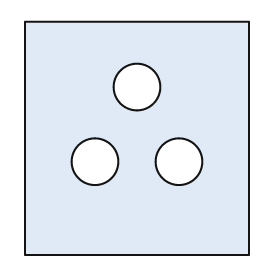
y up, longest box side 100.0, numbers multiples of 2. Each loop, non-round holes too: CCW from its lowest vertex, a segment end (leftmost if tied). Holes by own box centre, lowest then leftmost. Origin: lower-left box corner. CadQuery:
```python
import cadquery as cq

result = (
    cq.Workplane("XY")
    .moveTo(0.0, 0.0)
    .lineTo(96.0, 0.0)
    .lineTo(96.0, 100.0)
    .lineTo(0.0, 100.0)
    .close()
    .moveTo(30.0, 40.0)
    .circle(10.0)
    .moveTo(66.0, 40.0)
    .circle(10.0)
    .moveTo(48.0, 72.0)
    .circle(10.0)
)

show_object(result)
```